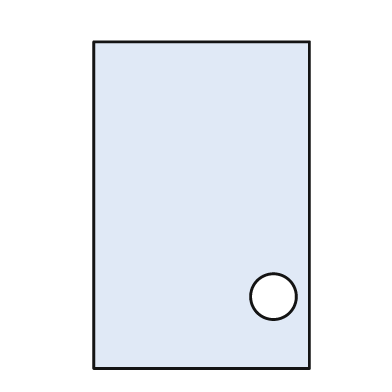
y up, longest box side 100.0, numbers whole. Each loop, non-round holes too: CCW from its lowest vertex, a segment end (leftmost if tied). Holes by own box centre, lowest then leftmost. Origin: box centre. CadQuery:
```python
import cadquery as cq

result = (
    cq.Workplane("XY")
    .moveTo(-33.0, -50.0)
    .lineTo(33.0, -50.0)
    .lineTo(33.0, 50.0)
    .lineTo(-33.0, 50.0)
    .close()
    .moveTo(22.0, -28.0)
    .circle(7.0)
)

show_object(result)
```